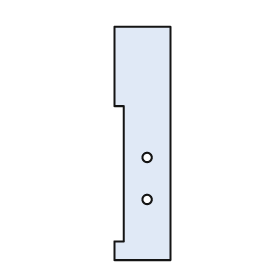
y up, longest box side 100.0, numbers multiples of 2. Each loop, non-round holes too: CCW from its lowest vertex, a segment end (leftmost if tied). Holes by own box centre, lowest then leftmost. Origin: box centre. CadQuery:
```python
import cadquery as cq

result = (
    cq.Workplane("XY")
    .moveTo(-12.0, -50.0)
    .lineTo(12.0, -50.0)
    .lineTo(12.0, 50.0)
    .lineTo(-12.0, 50.0)
    .lineTo(-12.0, 16.0)
    .lineTo(-8.0, 16.0)
    .lineTo(-8.0, -42.0)
    .lineTo(-12.0, -42.0)
    .close()
    .moveTo(2.0, -24.0)
    .circle(2.0)
    .moveTo(2.0, -6.0)
    .circle(2.0)
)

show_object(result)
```